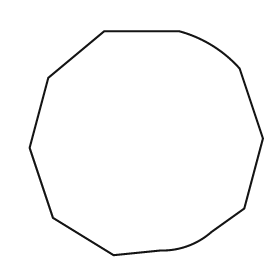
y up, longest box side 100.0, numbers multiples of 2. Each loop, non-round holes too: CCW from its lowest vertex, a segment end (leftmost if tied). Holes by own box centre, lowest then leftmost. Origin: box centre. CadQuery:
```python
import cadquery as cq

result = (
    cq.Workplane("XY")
    .moveTo(-14.0, -48.0)
    .lineTo(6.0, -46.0)
    .threePointArc((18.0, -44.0), (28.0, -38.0))
    .lineTo(42.0, -28.0)
    .lineTo(50.0, 2.0)
    .lineTo(40.0, 32.0)
    .threePointArc((28.0, 42.0), (14.0, 48.0))
    .lineTo(-18.0, 48.0)
    .lineTo(-42.0, 28.0)
    .lineTo(-50.0, -2.0)
    .lineTo(-40.0, -32.0)
    .close()
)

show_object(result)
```